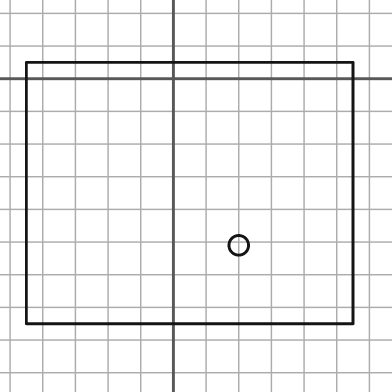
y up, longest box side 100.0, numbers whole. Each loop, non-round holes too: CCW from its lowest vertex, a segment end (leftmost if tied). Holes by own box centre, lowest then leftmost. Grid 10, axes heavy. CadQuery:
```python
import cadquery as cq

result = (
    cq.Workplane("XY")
    .moveTo(-45.0, -75.0)
    .lineTo(55.0, -75.0)
    .lineTo(55.0, 5.0)
    .lineTo(-45.0, 5.0)
    .close()
    .moveTo(20.0, -51.0)
    .circle(3.0)
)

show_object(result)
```